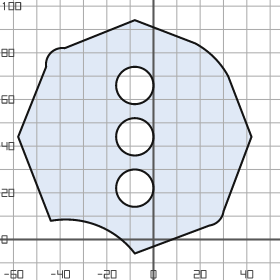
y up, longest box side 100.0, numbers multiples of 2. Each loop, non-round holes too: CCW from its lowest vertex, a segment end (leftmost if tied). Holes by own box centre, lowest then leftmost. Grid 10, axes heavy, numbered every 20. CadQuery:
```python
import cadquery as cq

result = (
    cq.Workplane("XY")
    .moveTo(-8.0, -6.0)
    .lineTo(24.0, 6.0)
    .threePointArc((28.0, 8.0), (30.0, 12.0))
    .lineTo(42.0, 44.0)
    .lineTo(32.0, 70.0)
    .threePointArc((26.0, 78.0), (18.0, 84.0))
    .lineTo(-8.0, 94.0)
    .lineTo(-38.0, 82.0)
    .threePointArc((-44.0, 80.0), (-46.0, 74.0))
    .lineTo(-58.0, 44.0)
    .lineTo(-44.0, 8.0)
    .threePointArc((-24.0, 6.0), (-8.0, -6.0))
    .close()
    .moveTo(-8.0, 22.0)
    .circle(8.0)
    .moveTo(-8.0, 44.0)
    .circle(8.0)
    .moveTo(-8.0, 66.0)
    .circle(8.0)
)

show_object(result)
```